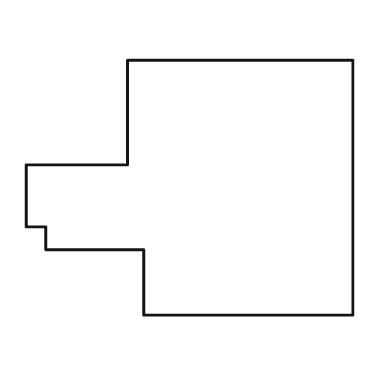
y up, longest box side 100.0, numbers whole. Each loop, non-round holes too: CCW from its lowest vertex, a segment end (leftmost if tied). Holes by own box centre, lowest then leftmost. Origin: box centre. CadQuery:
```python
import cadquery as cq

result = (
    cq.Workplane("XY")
    .moveTo(-14.0, -39.0)
    .lineTo(50.0, -39.0)
    .lineTo(50.0, 39.0)
    .lineTo(-19.0, 39.0)
    .lineTo(-19.0, 7.0)
    .lineTo(-50.0, 7.0)
    .lineTo(-50.0, -12.0)
    .lineTo(-44.0, -12.0)
    .lineTo(-44.0, -19.0)
    .lineTo(-14.0, -19.0)
    .close()
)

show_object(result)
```